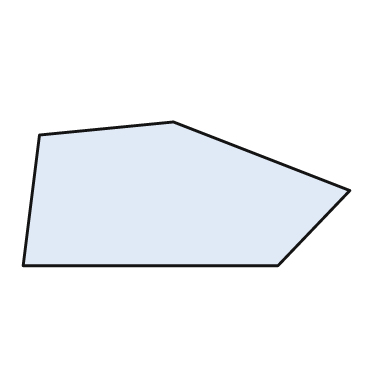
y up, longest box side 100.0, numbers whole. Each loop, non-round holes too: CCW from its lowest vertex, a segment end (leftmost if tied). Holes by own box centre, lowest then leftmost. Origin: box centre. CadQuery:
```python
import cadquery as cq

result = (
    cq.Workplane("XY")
    .moveTo(-50.0, -22.0)
    .lineTo(28.0, -22.0)
    .lineTo(50.0, 1.0)
    .lineTo(-4.0, 22.0)
    .lineTo(-45.0, 18.0)
    .close()
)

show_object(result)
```